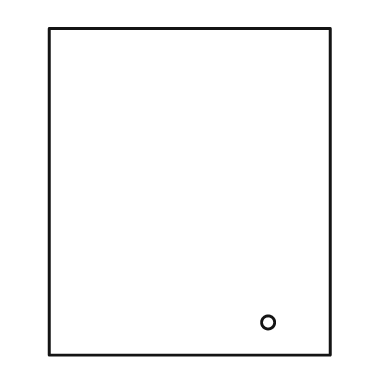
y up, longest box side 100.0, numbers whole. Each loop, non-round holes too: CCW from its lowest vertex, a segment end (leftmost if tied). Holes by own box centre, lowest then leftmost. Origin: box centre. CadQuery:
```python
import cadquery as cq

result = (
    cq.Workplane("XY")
    .moveTo(-43.0, -50.0)
    .lineTo(43.0, -50.0)
    .lineTo(43.0, 50.0)
    .lineTo(-43.0, 50.0)
    .close()
    .moveTo(24.0, -40.0)
    .circle(2.0)
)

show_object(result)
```